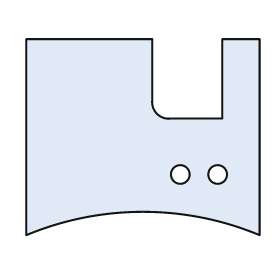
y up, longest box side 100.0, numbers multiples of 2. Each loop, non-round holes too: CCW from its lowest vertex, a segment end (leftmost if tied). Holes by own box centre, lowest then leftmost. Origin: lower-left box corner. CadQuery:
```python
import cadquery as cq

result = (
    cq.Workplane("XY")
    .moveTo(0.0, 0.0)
    .threePointArc((50.0, 10.0), (100.0, 0.0))
    .lineTo(100.0, 84.0)
    .lineTo(84.0, 84.0)
    .lineTo(84.0, 50.0)
    .lineTo(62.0, 50.0)
    .threePointArc((56.0, 52.0), (54.0, 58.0))
    .lineTo(54.0, 84.0)
    .lineTo(0.0, 84.0)
    .close()
    .moveTo(66.0, 26.0)
    .circle(4.0)
    .moveTo(82.0, 26.0)
    .circle(4.0)
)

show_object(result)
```